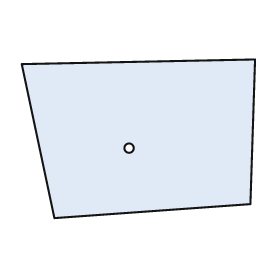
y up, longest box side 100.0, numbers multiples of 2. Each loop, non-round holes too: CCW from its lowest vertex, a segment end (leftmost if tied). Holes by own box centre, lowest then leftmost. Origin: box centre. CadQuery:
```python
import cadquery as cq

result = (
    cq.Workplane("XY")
    .moveTo(-36.0, -34.0)
    .lineTo(48.0, -28.0)
    .lineTo(50.0, 34.0)
    .lineTo(-50.0, 32.0)
    .close()
    .moveTo(-4.0, -4.0)
    .circle(2.0)
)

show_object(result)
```